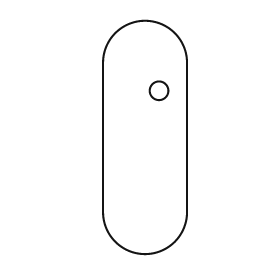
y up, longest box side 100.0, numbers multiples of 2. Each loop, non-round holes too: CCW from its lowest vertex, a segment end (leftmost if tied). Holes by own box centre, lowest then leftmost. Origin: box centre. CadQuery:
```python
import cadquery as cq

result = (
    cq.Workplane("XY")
    .moveTo(-18.0, -32.0)
    .threePointArc((0.0, -50.0), (18.0, -32.0))
    .lineTo(18.0, 32.0)
    .threePointArc((0.0, 50.0), (-18.0, 32.0))
    .close()
    .moveTo(6.0, 20.0)
    .circle(4.0)
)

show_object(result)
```